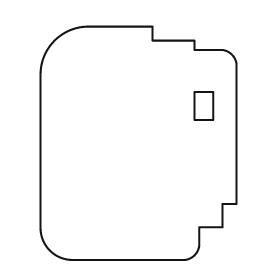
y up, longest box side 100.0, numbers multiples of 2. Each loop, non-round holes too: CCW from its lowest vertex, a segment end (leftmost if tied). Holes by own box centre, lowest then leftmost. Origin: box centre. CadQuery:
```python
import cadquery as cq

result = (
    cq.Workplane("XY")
    .moveTo(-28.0, -50.0)
    .lineTo(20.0, -50.0)
    .threePointArc((24.0, -48.0), (26.0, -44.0))
    .lineTo(26.0, -36.0)
    .lineTo(36.0, -36.0)
    .lineTo(36.0, -26.0)
    .lineTo(42.0, -26.0)
    .lineTo(42.0, 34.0)
    .threePointArc((40.0, 38.0), (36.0, 40.0))
    .lineTo(24.0, 40.0)
    .lineTo(24.0, 44.0)
    .lineTo(6.0, 44.0)
    .lineTo(6.0, 50.0)
    .lineTo(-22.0, 50.0)
    .threePointArc((-36.0, 44.0), (-42.0, 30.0))
    .lineTo(-42.0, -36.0)
    .threePointArc((-38.0, -46.0), (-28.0, -50.0))
    .close()
    .moveTo(24.0, 10.0)
    .lineTo(32.0, 10.0)
    .lineTo(32.0, 22.0)
    .lineTo(24.0, 22.0)
    .close()
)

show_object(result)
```